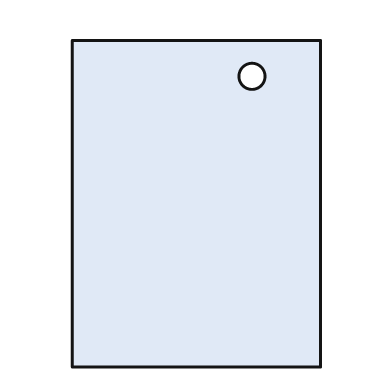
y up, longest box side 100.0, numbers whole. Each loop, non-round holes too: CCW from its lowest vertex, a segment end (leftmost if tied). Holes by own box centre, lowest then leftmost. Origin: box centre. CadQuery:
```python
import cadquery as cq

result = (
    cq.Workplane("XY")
    .moveTo(-38.0, -50.0)
    .lineTo(38.0, -50.0)
    .lineTo(38.0, 50.0)
    .lineTo(-38.0, 50.0)
    .close()
    .moveTo(17.0, 39.0)
    .circle(4.0)
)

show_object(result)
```